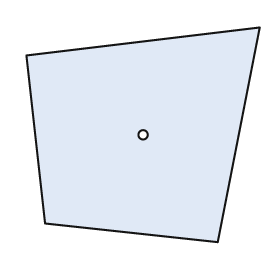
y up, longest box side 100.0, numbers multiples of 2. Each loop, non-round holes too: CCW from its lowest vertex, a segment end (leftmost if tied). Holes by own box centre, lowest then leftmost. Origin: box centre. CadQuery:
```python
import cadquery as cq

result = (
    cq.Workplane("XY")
    .moveTo(32.0, -46.0)
    .lineTo(50.0, 46.0)
    .lineTo(-50.0, 34.0)
    .lineTo(-42.0, -38.0)
    .close()
    .moveTo(0.0, 0.0)
    .circle(2.0)
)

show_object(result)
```